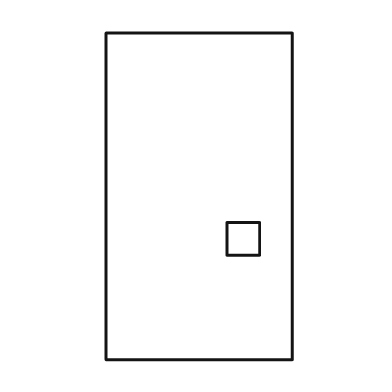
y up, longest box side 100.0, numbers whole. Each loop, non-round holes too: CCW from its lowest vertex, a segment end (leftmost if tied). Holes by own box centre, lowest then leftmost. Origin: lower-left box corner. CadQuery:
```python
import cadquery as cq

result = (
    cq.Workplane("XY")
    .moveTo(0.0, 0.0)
    .lineTo(57.0, 0.0)
    .lineTo(57.0, 100.0)
    .lineTo(0.0, 100.0)
    .close()
    .moveTo(37.0, 32.0)
    .lineTo(47.0, 32.0)
    .lineTo(47.0, 42.0)
    .lineTo(37.0, 42.0)
    .close()
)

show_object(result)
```